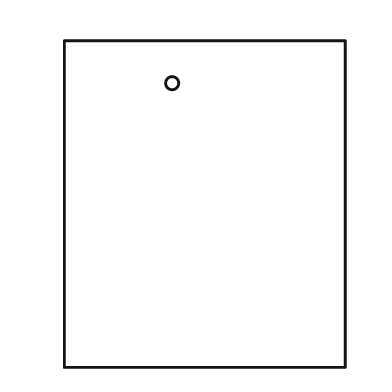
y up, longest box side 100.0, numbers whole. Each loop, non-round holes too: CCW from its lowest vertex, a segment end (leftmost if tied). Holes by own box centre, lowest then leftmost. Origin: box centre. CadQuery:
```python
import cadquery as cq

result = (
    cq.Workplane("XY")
    .moveTo(-43.0, -50.0)
    .lineTo(43.0, -50.0)
    .lineTo(43.0, 50.0)
    .lineTo(-43.0, 50.0)
    .close()
    .moveTo(-10.0, 37.0)
    .circle(2.0)
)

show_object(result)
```